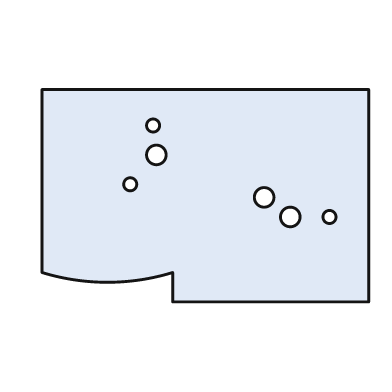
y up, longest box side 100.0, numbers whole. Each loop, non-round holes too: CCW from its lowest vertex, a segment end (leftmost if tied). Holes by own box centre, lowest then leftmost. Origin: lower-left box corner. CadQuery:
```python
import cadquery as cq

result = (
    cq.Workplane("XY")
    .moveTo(40.0, 0.0)
    .lineTo(100.0, 0.0)
    .lineTo(100.0, 65.0)
    .lineTo(0.0, 65.0)
    .lineTo(0.0, 9.0)
    .threePointArc((20.0, 6.0), (40.0, 9.0))
    .close()
    .moveTo(76.0, 26.0)
    .circle(3.0)
    .moveTo(88.0, 26.0)
    .circle(2.0)
    .moveTo(68.0, 32.0)
    .circle(3.0)
    .moveTo(27.0, 36.0)
    .circle(2.0)
    .moveTo(35.0, 45.0)
    .circle(3.0)
    .moveTo(34.0, 54.0)
    .circle(2.0)
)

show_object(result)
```